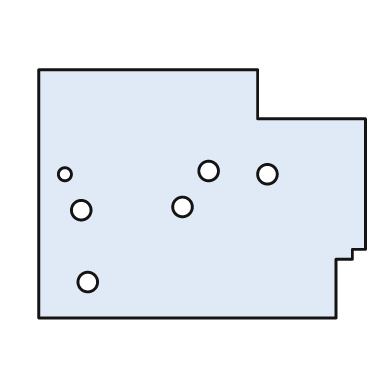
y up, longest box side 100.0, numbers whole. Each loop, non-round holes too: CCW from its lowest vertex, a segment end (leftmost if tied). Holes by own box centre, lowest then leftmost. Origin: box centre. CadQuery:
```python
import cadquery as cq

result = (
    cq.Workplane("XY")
    .moveTo(-50.0, -38.0)
    .lineTo(41.0, -38.0)
    .lineTo(41.0, -20.0)
    .lineTo(46.0, -20.0)
    .lineTo(46.0, -17.0)
    .lineTo(50.0, -17.0)
    .lineTo(50.0, 23.0)
    .lineTo(17.0, 23.0)
    .lineTo(17.0, 38.0)
    .lineTo(-50.0, 38.0)
    .close()
    .moveTo(-35.0, -27.0)
    .circle(3.0)
    .moveTo(-37.0, -5.0)
    .circle(3.0)
    .moveTo(-6.0, -4.0)
    .circle(3.0)
    .moveTo(-42.0, 6.0)
    .circle(2.0)
    .moveTo(20.0, 6.0)
    .circle(3.0)
    .moveTo(2.0, 7.0)
    .circle(3.0)
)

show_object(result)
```